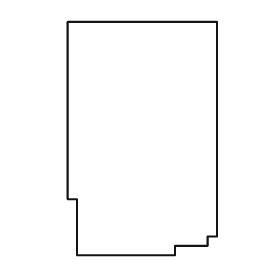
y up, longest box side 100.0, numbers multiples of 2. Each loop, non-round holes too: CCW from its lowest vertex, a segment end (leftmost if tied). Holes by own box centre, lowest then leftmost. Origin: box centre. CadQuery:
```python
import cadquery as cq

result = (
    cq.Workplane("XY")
    .moveTo(-28.0, -50.0)
    .lineTo(14.0, -50.0)
    .lineTo(14.0, -46.0)
    .lineTo(28.0, -46.0)
    .lineTo(28.0, -42.0)
    .lineTo(32.0, -42.0)
    .lineTo(32.0, 50.0)
    .lineTo(-32.0, 50.0)
    .lineTo(-32.0, -26.0)
    .lineTo(-28.0, -26.0)
    .close()
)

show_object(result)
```